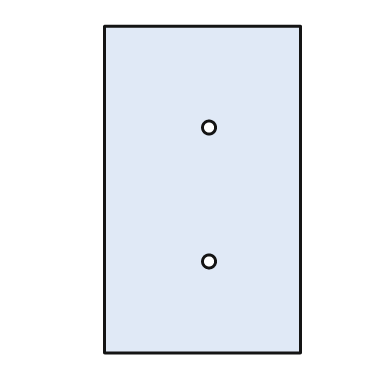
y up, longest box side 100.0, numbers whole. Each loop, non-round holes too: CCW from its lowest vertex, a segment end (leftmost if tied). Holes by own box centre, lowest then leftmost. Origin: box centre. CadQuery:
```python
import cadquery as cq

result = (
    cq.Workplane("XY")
    .moveTo(-30.0, -50.0)
    .lineTo(30.0, -50.0)
    .lineTo(30.0, 50.0)
    .lineTo(-30.0, 50.0)
    .close()
    .moveTo(2.0, -22.0)
    .circle(2.0)
    .moveTo(2.0, 19.0)
    .circle(2.0)
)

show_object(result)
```